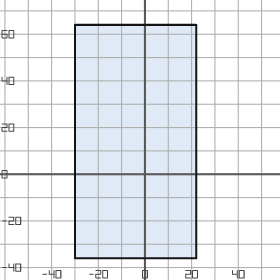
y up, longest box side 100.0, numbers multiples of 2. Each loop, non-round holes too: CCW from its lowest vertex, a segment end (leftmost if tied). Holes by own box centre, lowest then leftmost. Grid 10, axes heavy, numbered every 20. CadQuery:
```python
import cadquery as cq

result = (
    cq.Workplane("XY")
    .moveTo(-30.0, -36.0)
    .lineTo(22.0, -36.0)
    .lineTo(22.0, 64.0)
    .lineTo(-30.0, 64.0)
    .close()
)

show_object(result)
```